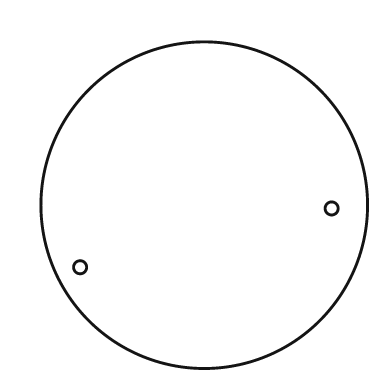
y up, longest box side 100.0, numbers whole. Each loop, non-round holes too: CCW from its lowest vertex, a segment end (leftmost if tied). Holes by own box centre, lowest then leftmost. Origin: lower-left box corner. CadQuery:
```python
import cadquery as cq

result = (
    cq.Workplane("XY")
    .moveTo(50.0, 50.0)
    .circle(50.0)
    .moveTo(12.0, 31.0)
    .circle(2.0)
    .moveTo(89.0, 49.0)
    .circle(2.0)
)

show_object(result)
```